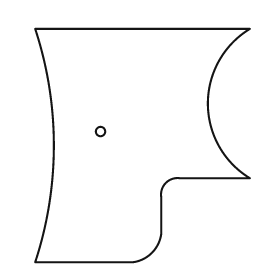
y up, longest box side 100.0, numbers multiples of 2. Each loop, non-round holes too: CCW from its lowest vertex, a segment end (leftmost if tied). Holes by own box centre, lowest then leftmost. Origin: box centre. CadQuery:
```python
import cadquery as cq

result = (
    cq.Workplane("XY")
    .moveTo(-46.0, -50.0)
    .lineTo(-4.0, -50.0)
    .threePointArc((4.0, -46.0), (8.0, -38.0))
    .lineTo(8.0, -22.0)
    .threePointArc((10.0, -16.0), (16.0, -14.0))
    .lineTo(46.0, -14.0)
    .threePointArc((28.0, 18.0), (46.0, 50.0))
    .lineTo(-46.0, 50.0)
    .threePointArc((-38.0, 0.0), (-46.0, -50.0))
    .close()
    .moveTo(-18.0, 6.0)
    .circle(2.0)
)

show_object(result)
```